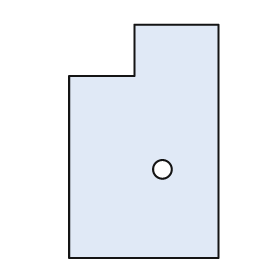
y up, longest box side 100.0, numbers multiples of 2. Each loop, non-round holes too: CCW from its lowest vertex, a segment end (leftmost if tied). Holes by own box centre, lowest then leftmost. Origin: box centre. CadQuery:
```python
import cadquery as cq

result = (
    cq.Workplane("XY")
    .moveTo(-32.0, -50.0)
    .lineTo(32.0, -50.0)
    .lineTo(32.0, 50.0)
    .lineTo(-4.0, 50.0)
    .lineTo(-4.0, 28.0)
    .lineTo(-32.0, 28.0)
    .close()
    .moveTo(8.0, -12.0)
    .circle(4.0)
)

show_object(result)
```